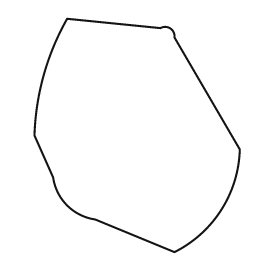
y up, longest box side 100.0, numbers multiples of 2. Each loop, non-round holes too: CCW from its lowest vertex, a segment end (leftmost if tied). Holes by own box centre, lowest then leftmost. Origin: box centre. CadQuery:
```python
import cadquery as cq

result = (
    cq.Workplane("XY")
    .moveTo(16.0, -50.0)
    .threePointArc((36.0, -32.0), (44.0, -6.0))
    .lineTo(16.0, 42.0)
    .threePointArc((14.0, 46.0), (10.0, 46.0))
    .lineTo(-30.0, 50.0)
    .threePointArc((-40.0, 26.0), (-44.0, 0.0))
    .lineTo(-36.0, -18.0)
    .threePointArc((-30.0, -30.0), (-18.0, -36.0))
    .close()
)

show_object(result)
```